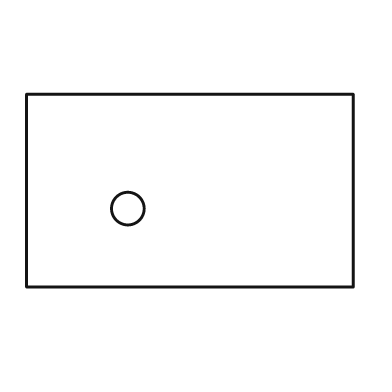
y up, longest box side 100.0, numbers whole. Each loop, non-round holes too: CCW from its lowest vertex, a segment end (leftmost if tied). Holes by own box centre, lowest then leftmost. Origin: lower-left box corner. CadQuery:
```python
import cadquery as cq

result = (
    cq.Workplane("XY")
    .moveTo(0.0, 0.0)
    .lineTo(100.0, 0.0)
    .lineTo(100.0, 59.0)
    .lineTo(0.0, 59.0)
    .close()
    .moveTo(31.0, 24.0)
    .circle(5.0)
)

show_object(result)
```